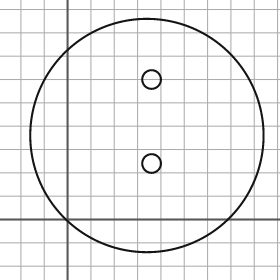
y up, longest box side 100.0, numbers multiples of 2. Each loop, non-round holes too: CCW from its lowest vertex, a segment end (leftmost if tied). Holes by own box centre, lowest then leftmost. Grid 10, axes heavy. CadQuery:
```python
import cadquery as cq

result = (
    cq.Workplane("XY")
    .moveTo(34.0, 36.0)
    .circle(50.0)
    .moveTo(36.0, 24.0)
    .circle(4.0)
    .moveTo(36.0, 60.0)
    .circle(4.0)
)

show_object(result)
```